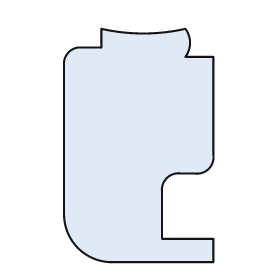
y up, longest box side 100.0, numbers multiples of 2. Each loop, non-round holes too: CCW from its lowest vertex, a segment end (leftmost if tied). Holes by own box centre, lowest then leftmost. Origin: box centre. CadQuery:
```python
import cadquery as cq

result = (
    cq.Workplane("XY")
    .moveTo(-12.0, -50.0)
    .lineTo(32.0, -50.0)
    .lineTo(32.0, -40.0)
    .lineTo(10.0, -40.0)
    .lineTo(10.0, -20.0)
    .threePointArc((12.0, -14.0), (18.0, -12.0))
    .lineTo(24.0, -12.0)
    .threePointArc((30.0, -10.0), (32.0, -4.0))
    .lineTo(32.0, 38.0)
    .lineTo(20.0, 38.0)
    .threePointArc((22.0, 44.0), (20.0, 50.0))
    .threePointArc((2.0, 48.0), (-16.0, 50.0))
    .lineTo(-16.0, 42.0)
    .lineTo(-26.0, 42.0)
    .threePointArc((-30.0, 40.0), (-32.0, 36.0))
    .lineTo(-32.0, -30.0)
    .threePointArc((-26.0, -44.0), (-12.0, -50.0))
    .close()
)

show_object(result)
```